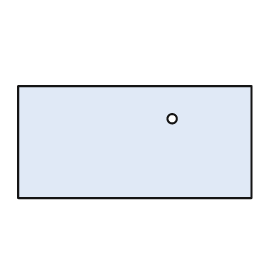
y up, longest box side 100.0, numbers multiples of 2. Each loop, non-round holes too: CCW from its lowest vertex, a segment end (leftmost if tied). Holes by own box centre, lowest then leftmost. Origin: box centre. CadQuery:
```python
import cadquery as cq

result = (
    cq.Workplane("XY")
    .moveTo(-50.0, -24.0)
    .lineTo(50.0, -24.0)
    .lineTo(50.0, 24.0)
    .lineTo(-50.0, 24.0)
    .close()
    .moveTo(16.0, 10.0)
    .circle(2.0)
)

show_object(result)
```